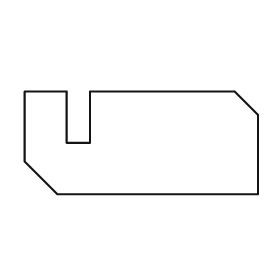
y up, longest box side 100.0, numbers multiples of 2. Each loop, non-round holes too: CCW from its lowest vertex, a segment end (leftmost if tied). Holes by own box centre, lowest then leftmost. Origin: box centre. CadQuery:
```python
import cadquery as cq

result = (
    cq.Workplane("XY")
    .moveTo(-36.0, -22.0)
    .lineTo(50.0, -22.0)
    .lineTo(50.0, 12.0)
    .lineTo(40.0, 22.0)
    .lineTo(-22.0, 22.0)
    .lineTo(-22.0, 0.0)
    .lineTo(-32.0, 0.0)
    .lineTo(-32.0, 22.0)
    .lineTo(-50.0, 22.0)
    .lineTo(-50.0, -8.0)
    .close()
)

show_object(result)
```